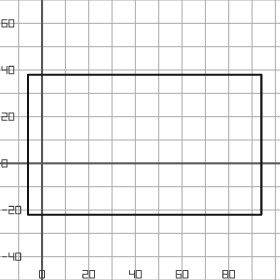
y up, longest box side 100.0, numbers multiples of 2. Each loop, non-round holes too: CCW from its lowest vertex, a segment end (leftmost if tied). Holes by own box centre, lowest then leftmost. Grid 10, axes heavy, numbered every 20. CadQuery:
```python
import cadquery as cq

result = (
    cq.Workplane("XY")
    .moveTo(-6.0, -22.0)
    .lineTo(94.0, -22.0)
    .lineTo(94.0, 38.0)
    .lineTo(-6.0, 38.0)
    .close()
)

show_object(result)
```